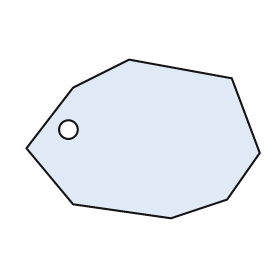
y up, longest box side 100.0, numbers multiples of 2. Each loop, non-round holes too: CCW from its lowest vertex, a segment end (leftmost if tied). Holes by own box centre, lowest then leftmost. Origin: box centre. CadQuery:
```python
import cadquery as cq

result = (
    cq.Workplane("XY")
    .moveTo(12.0, -34.0)
    .lineTo(36.0, -26.0)
    .lineTo(50.0, -6.0)
    .lineTo(38.0, 26.0)
    .lineTo(-6.0, 34.0)
    .lineTo(-30.0, 22.0)
    .lineTo(-50.0, -4.0)
    .lineTo(-30.0, -28.0)
    .close()
    .moveTo(-32.0, 4.0)
    .circle(4.0)
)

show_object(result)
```